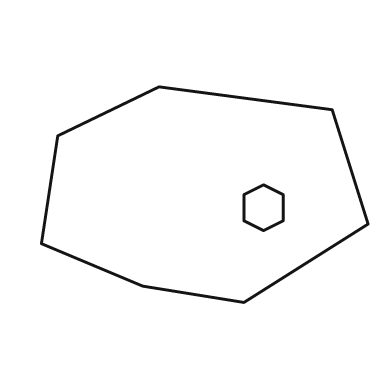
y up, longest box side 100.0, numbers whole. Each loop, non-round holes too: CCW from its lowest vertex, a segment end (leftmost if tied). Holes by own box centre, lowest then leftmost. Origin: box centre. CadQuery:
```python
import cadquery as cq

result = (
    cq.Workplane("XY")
    .moveTo(12.0, -33.0)
    .lineTo(50.0, -9.0)
    .lineTo(39.0, 26.0)
    .lineTo(-14.0, 33.0)
    .lineTo(-45.0, 18.0)
    .lineTo(-50.0, -15.0)
    .lineTo(-19.0, -28.0)
    .close()
    .moveTo(18.0, -11.0)
    .lineTo(24.0, -8.0)
    .lineTo(24.0, 0.0)
    .lineTo(18.0, 3.0)
    .lineTo(12.0, 0.0)
    .lineTo(12.0, -8.0)
    .close()
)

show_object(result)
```